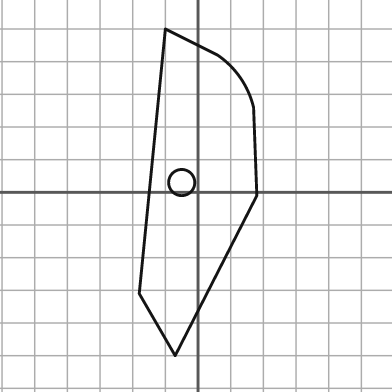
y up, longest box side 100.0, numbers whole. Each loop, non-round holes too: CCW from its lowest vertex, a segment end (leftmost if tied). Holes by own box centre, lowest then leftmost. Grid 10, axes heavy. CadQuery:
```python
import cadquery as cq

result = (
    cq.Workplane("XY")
    .moveTo(-7.0, -50.0)
    .lineTo(18.0, -1.0)
    .lineTo(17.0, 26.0)
    .threePointArc((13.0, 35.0), (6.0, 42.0))
    .lineTo(-10.0, 50.0)
    .lineTo(-18.0, -31.0)
    .close()
    .moveTo(-5.0, 3.0)
    .circle(4.0)
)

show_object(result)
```